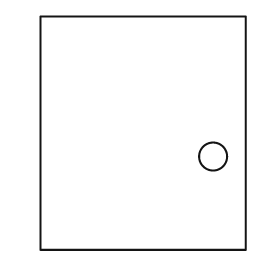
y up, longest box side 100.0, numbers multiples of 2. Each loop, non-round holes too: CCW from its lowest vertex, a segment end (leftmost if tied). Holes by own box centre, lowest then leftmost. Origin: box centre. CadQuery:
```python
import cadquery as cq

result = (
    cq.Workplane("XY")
    .moveTo(-44.0, -50.0)
    .lineTo(44.0, -50.0)
    .lineTo(44.0, 50.0)
    .lineTo(-44.0, 50.0)
    .close()
    .moveTo(30.0, -10.0)
    .circle(6.0)
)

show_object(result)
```